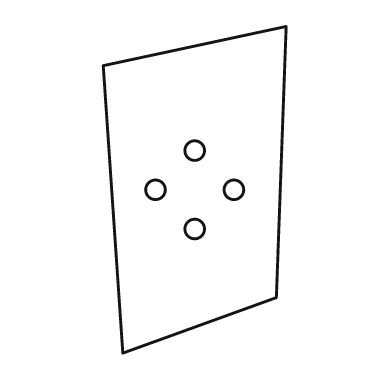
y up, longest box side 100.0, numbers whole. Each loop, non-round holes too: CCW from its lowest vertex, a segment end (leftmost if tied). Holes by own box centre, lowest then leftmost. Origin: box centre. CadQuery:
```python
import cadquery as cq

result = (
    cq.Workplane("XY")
    .moveTo(-22.0, -50.0)
    .lineTo(25.0, -33.0)
    .lineTo(28.0, 50.0)
    .lineTo(-28.0, 38.0)
    .close()
    .moveTo(0.0, -12.0)
    .circle(3.0)
    .moveTo(-12.0, 0.0)
    .circle(3.0)
    .moveTo(12.0, 0.0)
    .circle(3.0)
    .moveTo(0.0, 12.0)
    .circle(3.0)
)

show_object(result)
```